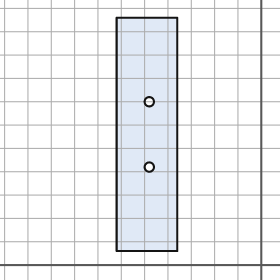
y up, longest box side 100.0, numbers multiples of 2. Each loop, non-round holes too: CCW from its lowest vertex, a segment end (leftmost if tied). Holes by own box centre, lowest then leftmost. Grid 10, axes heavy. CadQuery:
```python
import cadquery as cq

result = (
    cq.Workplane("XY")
    .moveTo(-62.0, 6.0)
    .lineTo(-36.0, 6.0)
    .lineTo(-36.0, 106.0)
    .lineTo(-62.0, 106.0)
    .close()
    .moveTo(-48.0, 42.0)
    .circle(2.0)
    .moveTo(-48.0, 70.0)
    .circle(2.0)
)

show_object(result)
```